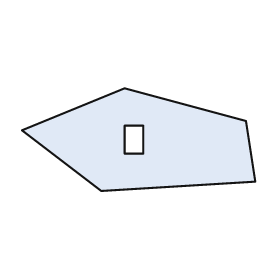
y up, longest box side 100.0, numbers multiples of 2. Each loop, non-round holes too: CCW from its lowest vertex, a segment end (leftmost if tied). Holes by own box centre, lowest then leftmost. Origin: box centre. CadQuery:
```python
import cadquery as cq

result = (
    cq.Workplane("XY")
    .moveTo(-16.0, -22.0)
    .lineTo(50.0, -18.0)
    .lineTo(46.0, 8.0)
    .lineTo(-6.0, 22.0)
    .lineTo(-50.0, 4.0)
    .close()
    .moveTo(-6.0, -6.0)
    .lineTo(2.0, -6.0)
    .lineTo(2.0, 6.0)
    .lineTo(-6.0, 6.0)
    .close()
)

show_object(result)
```